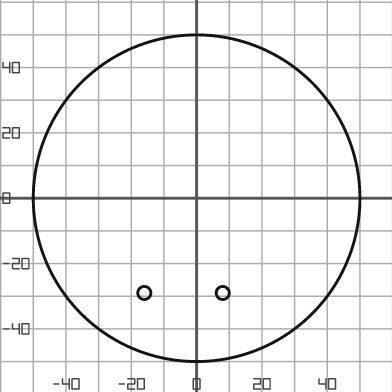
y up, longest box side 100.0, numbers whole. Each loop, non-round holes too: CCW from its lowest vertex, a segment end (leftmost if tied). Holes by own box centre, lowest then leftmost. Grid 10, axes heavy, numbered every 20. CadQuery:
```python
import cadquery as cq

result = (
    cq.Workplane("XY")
    .moveTo(0.0, 0.0)
    .circle(50.0)
    .moveTo(-16.0, -29.0)
    .circle(2.0)
    .moveTo(8.0, -29.0)
    .circle(2.0)
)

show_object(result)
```